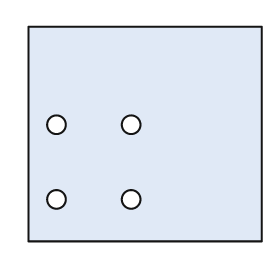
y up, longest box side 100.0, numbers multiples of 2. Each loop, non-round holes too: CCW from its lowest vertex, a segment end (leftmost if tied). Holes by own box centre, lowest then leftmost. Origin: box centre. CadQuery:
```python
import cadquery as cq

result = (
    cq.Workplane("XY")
    .moveTo(-50.0, -46.0)
    .lineTo(50.0, -46.0)
    .lineTo(50.0, 46.0)
    .lineTo(-50.0, 46.0)
    .close()
    .moveTo(-38.0, -28.0)
    .circle(4.0)
    .moveTo(-6.0, -28.0)
    .circle(4.0)
    .moveTo(-38.0, 4.0)
    .circle(4.0)
    .moveTo(-6.0, 4.0)
    .circle(4.0)
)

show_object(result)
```